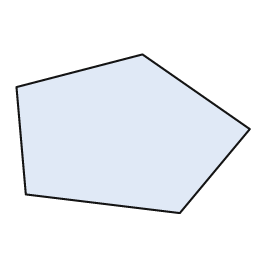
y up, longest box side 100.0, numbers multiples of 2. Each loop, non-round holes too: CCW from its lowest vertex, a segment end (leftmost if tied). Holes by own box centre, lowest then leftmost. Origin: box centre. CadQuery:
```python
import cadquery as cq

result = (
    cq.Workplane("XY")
    .moveTo(20.0, -34.0)
    .lineTo(50.0, 2.0)
    .lineTo(4.0, 34.0)
    .lineTo(-50.0, 20.0)
    .lineTo(-46.0, -26.0)
    .close()
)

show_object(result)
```